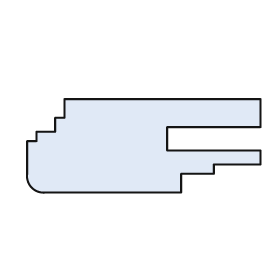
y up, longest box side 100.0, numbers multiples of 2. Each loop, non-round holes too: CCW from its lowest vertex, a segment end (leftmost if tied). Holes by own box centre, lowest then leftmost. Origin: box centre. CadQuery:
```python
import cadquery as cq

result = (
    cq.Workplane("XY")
    .moveTo(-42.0, -20.0)
    .lineTo(16.0, -20.0)
    .lineTo(16.0, -12.0)
    .lineTo(30.0, -12.0)
    .lineTo(30.0, -8.0)
    .lineTo(50.0, -8.0)
    .lineTo(50.0, -2.0)
    .lineTo(10.0, -2.0)
    .lineTo(10.0, 8.0)
    .lineTo(50.0, 8.0)
    .lineTo(50.0, 20.0)
    .lineTo(-34.0, 20.0)
    .lineTo(-34.0, 12.0)
    .lineTo(-38.0, 12.0)
    .lineTo(-38.0, 6.0)
    .lineTo(-46.0, 6.0)
    .lineTo(-46.0, 2.0)
    .lineTo(-50.0, 2.0)
    .lineTo(-50.0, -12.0)
    .threePointArc((-48.0, -18.0), (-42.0, -20.0))
    .close()
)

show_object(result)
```